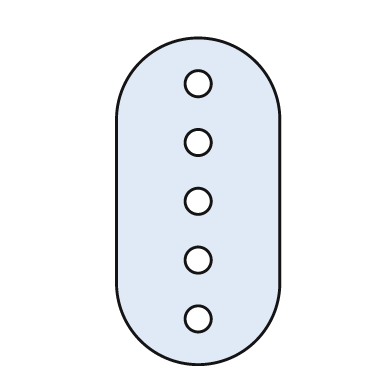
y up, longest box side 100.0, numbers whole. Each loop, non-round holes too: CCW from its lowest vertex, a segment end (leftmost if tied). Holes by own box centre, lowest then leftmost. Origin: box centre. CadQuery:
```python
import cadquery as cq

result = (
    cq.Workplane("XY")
    .moveTo(-25.0, -25.0)
    .threePointArc((0.0, -50.0), (25.0, -25.0))
    .lineTo(25.0, 25.0)
    .threePointArc((0.0, 50.0), (-25.0, 25.0))
    .close()
    .moveTo(0.0, -36.0)
    .circle(4.0)
    .moveTo(0.0, -18.0)
    .circle(4.0)
    .moveTo(0.0, 0.0)
    .circle(4.0)
    .moveTo(0.0, 18.0)
    .circle(4.0)
    .moveTo(0.0, 36.0)
    .circle(4.0)
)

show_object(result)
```